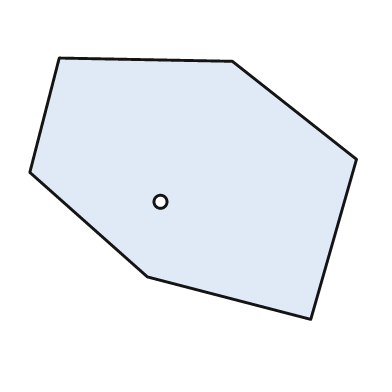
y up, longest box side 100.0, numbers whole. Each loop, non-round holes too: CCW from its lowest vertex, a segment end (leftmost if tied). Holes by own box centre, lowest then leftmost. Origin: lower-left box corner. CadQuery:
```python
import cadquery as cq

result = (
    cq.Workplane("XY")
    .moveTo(86.0, 0.0)
    .lineTo(100.0, 49.0)
    .lineTo(62.0, 79.0)
    .lineTo(9.0, 80.0)
    .lineTo(0.0, 45.0)
    .lineTo(36.0, 13.0)
    .close()
    .moveTo(40.0, 36.0)
    .circle(2.0)
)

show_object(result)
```